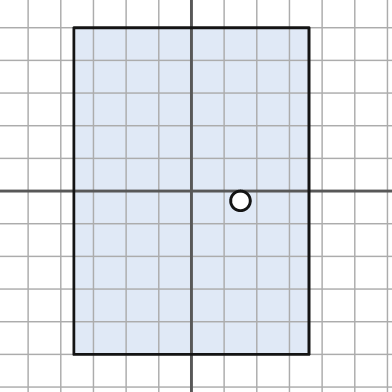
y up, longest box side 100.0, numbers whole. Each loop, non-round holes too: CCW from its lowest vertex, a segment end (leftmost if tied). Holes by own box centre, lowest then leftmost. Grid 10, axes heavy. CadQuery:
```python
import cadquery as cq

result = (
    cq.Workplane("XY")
    .moveTo(-36.0, -50.0)
    .lineTo(36.0, -50.0)
    .lineTo(36.0, 50.0)
    .lineTo(-36.0, 50.0)
    .close()
    .moveTo(15.0, -3.0)
    .circle(3.0)
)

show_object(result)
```